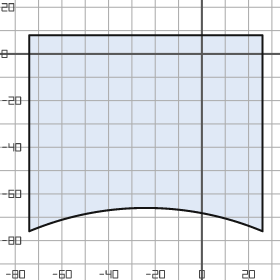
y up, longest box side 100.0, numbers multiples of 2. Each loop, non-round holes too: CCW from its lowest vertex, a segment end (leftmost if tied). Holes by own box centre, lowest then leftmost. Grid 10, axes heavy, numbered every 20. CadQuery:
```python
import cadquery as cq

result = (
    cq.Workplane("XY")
    .moveTo(-74.0, -76.0)
    .threePointArc((-24.0, -66.0), (26.0, -76.0))
    .lineTo(26.0, 8.0)
    .lineTo(-74.0, 8.0)
    .close()
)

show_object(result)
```